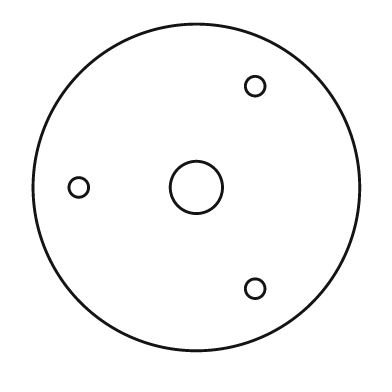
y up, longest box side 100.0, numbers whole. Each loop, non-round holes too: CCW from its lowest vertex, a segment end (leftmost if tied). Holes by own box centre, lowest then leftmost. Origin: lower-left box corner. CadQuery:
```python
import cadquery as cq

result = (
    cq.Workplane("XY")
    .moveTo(50.0, 50.0)
    .circle(50.0)
    .moveTo(68.0, 19.0)
    .circle(3.0)
    .moveTo(14.0, 50.0)
    .circle(3.0)
    .moveTo(50.0, 50.0)
    .circle(8.0)
    .moveTo(68.0, 81.0)
    .circle(3.0)
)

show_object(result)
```